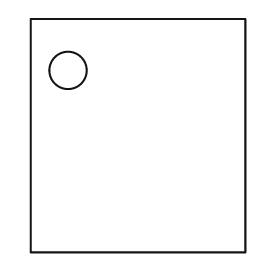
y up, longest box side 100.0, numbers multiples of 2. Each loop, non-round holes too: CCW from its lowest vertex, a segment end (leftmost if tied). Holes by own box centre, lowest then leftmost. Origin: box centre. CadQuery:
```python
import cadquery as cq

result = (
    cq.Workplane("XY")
    .moveTo(-46.0, -50.0)
    .lineTo(46.0, -50.0)
    .lineTo(46.0, 50.0)
    .lineTo(-46.0, 50.0)
    .close()
    .moveTo(-30.0, 28.0)
    .circle(8.0)
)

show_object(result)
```